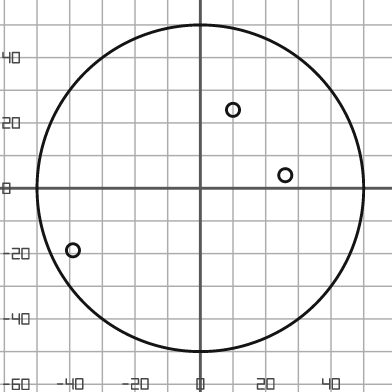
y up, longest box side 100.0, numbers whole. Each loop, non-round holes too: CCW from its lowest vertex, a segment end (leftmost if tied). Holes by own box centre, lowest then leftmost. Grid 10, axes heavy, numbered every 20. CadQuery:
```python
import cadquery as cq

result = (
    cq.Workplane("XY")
    .moveTo(0.0, 0.0)
    .circle(50.0)
    .moveTo(-39.0, -19.0)
    .circle(2.0)
    .moveTo(26.0, 4.0)
    .circle(2.0)
    .moveTo(10.0, 24.0)
    .circle(2.0)
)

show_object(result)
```